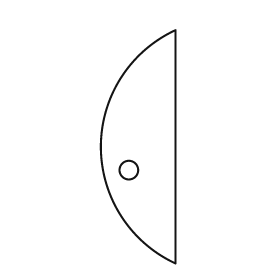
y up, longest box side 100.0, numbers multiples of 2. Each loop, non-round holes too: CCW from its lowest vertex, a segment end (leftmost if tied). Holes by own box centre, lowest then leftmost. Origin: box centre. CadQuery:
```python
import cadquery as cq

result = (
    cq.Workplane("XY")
    .moveTo(16.0, -50.0)
    .lineTo(16.0, 50.0)
    .threePointArc((-16.0, 0.0), (16.0, -50.0))
    .close()
    .moveTo(-4.0, -10.0)
    .circle(4.0)
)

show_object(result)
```